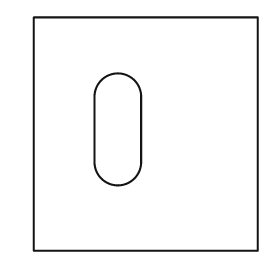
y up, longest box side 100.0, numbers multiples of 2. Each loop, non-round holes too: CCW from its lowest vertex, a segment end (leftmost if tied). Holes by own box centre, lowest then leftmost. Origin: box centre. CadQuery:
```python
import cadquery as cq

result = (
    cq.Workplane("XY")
    .moveTo(-48.0, -50.0)
    .lineTo(48.0, -50.0)
    .lineTo(48.0, 50.0)
    .lineTo(-48.0, 50.0)
    .close()
    .moveTo(-22.0, -12.0)
    .threePointArc((-12.0, -22.0), (-2.0, -12.0))
    .lineTo(-2.0, 16.0)
    .threePointArc((-12.0, 26.0), (-22.0, 16.0))
    .close()
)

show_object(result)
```